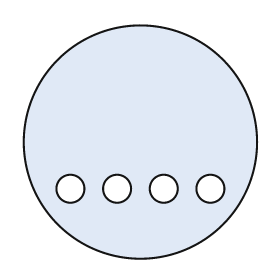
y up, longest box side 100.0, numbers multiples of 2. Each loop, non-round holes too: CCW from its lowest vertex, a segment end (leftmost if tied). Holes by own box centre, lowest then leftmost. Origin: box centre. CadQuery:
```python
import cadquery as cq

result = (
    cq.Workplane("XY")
    .moveTo(0.0, 0.0)
    .circle(50.0)
    .moveTo(-30.0, -20.0)
    .circle(6.0)
    .moveTo(-10.0, -20.0)
    .circle(6.0)
    .moveTo(10.0, -20.0)
    .circle(6.0)
    .moveTo(30.0, -20.0)
    .circle(6.0)
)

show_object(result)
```